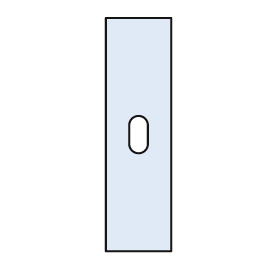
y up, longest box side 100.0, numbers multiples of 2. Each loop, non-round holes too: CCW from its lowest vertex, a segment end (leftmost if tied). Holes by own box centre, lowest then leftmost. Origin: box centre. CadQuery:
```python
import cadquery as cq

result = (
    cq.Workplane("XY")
    .moveTo(-14.0, -50.0)
    .lineTo(14.0, -50.0)
    .lineTo(14.0, 50.0)
    .lineTo(-14.0, 50.0)
    .close()
    .moveTo(-4.0, -4.0)
    .threePointArc((0.0, -8.0), (4.0, -4.0))
    .lineTo(4.0, 4.0)
    .threePointArc((0.0, 8.0), (-4.0, 4.0))
    .close()
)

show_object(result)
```